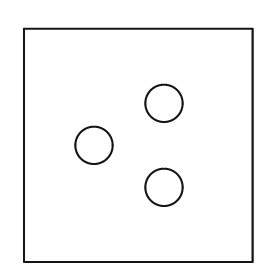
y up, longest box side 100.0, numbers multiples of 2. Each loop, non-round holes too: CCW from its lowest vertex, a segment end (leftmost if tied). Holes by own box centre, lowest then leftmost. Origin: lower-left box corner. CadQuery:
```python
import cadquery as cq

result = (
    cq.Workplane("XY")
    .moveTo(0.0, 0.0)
    .lineTo(98.0, 0.0)
    .lineTo(98.0, 100.0)
    .lineTo(0.0, 100.0)
    .close()
    .moveTo(60.0, 32.0)
    .circle(8.0)
    .moveTo(30.0, 50.0)
    .circle(8.0)
    .moveTo(60.0, 68.0)
    .circle(8.0)
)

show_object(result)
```